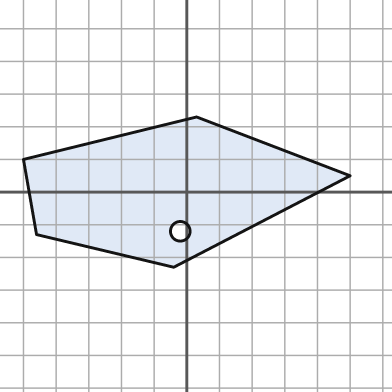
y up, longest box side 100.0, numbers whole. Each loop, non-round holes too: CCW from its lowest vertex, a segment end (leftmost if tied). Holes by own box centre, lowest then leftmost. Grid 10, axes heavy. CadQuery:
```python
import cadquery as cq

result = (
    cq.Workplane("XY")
    .moveTo(-4.0, -23.0)
    .lineTo(50.0, 5.0)
    .lineTo(3.0, 23.0)
    .lineTo(-50.0, 10.0)
    .lineTo(-46.0, -13.0)
    .close()
    .moveTo(-2.0, -12.0)
    .circle(3.0)
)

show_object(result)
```